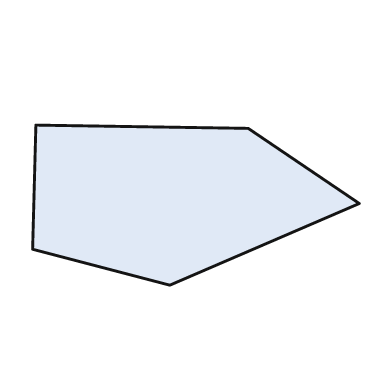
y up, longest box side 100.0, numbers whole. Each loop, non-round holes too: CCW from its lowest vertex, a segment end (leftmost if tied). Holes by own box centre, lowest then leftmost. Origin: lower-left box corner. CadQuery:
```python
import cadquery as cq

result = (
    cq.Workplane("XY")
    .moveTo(42.0, 0.0)
    .lineTo(100.0, 25.0)
    .lineTo(66.0, 48.0)
    .lineTo(1.0, 49.0)
    .lineTo(0.0, 11.0)
    .close()
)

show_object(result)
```